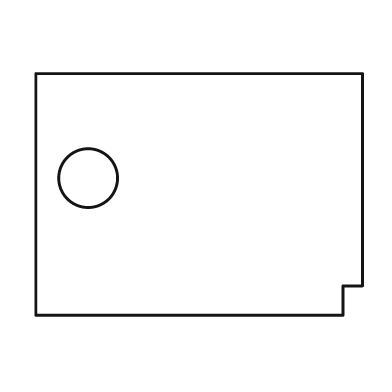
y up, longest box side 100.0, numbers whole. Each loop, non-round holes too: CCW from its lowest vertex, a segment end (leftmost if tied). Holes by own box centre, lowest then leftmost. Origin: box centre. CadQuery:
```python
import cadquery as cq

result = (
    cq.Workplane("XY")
    .moveTo(-50.0, -37.0)
    .lineTo(44.0, -37.0)
    .lineTo(44.0, -28.0)
    .lineTo(50.0, -28.0)
    .lineTo(50.0, 37.0)
    .lineTo(-50.0, 37.0)
    .close()
    .moveTo(-34.0, 5.0)
    .circle(9.0)
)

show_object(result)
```